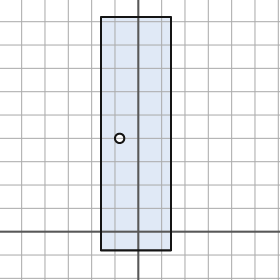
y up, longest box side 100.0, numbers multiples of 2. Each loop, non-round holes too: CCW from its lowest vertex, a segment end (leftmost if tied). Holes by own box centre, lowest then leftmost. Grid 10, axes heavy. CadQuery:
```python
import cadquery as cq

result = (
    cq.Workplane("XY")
    .moveTo(-16.0, -8.0)
    .lineTo(14.0, -8.0)
    .lineTo(14.0, 92.0)
    .lineTo(-16.0, 92.0)
    .close()
    .moveTo(-8.0, 40.0)
    .circle(2.0)
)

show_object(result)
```